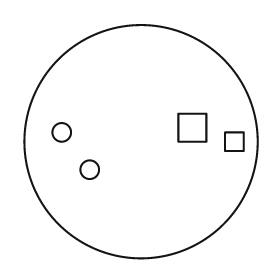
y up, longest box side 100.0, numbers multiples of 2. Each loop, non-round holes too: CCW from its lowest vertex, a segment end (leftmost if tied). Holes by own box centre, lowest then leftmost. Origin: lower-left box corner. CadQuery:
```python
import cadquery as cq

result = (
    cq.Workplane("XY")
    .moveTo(50.0, 50.0)
    .circle(50.0)
    .moveTo(28.0, 38.0)
    .circle(4.0)
    .moveTo(86.0, 46.0)
    .lineTo(94.0, 46.0)
    .lineTo(94.0, 54.0)
    .lineTo(86.0, 54.0)
    .close()
    .moveTo(16.0, 54.0)
    .circle(4.0)
    .moveTo(66.0, 50.0)
    .lineTo(78.0, 50.0)
    .lineTo(78.0, 62.0)
    .lineTo(66.0, 62.0)
    .close()
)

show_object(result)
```